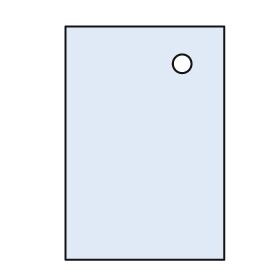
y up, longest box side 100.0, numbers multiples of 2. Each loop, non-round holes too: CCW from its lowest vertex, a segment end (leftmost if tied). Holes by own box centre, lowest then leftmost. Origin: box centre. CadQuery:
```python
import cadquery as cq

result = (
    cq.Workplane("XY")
    .moveTo(-34.0, -50.0)
    .lineTo(34.0, -50.0)
    .lineTo(34.0, 50.0)
    .lineTo(-34.0, 50.0)
    .close()
    .moveTo(16.0, 34.0)
    .circle(4.0)
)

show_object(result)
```